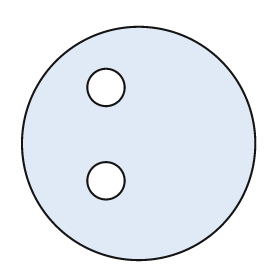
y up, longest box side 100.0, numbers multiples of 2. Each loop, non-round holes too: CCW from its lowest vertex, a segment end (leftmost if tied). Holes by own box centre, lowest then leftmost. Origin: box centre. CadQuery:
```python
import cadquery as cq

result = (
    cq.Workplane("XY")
    .moveTo(0.0, 0.0)
    .circle(50.0)
    .moveTo(-14.0, -16.0)
    .circle(8.0)
    .moveTo(-14.0, 24.0)
    .circle(8.0)
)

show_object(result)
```